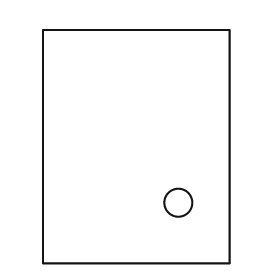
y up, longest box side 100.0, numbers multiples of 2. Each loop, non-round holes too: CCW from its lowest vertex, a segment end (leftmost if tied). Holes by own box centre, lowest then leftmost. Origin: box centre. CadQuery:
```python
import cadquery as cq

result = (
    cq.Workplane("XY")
    .moveTo(-40.0, -50.0)
    .lineTo(40.0, -50.0)
    .lineTo(40.0, 50.0)
    .lineTo(-40.0, 50.0)
    .close()
    .moveTo(18.0, -24.0)
    .circle(6.0)
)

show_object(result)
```